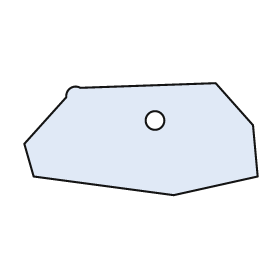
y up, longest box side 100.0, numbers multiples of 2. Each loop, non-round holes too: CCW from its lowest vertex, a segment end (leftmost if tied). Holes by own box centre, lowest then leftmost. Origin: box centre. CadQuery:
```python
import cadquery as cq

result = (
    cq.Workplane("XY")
    .moveTo(14.0, -24.0)
    .lineTo(50.0, -16.0)
    .lineTo(48.0, 6.0)
    .lineTo(32.0, 24.0)
    .lineTo(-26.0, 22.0)
    .threePointArc((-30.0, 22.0), (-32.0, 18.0))
    .lineTo(-50.0, -2.0)
    .lineTo(-46.0, -16.0)
    .close()
    .moveTo(6.0, 8.0)
    .circle(4.0)
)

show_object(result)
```